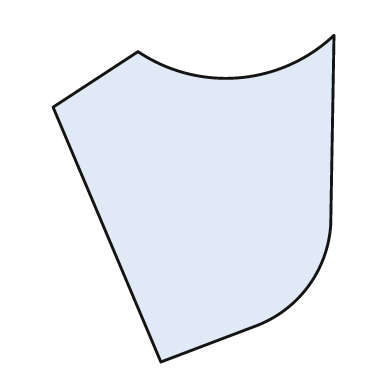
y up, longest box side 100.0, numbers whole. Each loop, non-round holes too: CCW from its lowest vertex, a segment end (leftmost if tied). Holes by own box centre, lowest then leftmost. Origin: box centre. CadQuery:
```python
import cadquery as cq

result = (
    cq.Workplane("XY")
    .moveTo(-10.0, -50.0)
    .lineTo(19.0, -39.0)
    .threePointArc((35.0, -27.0), (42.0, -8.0))
    .lineTo(43.0, 50.0)
    .threePointArc((14.0, 37.0), (-17.0, 45.0))
    .lineTo(-43.0, 28.0)
    .close()
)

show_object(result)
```